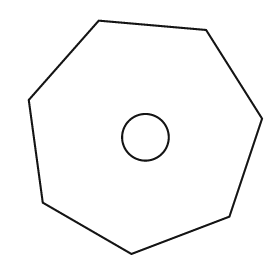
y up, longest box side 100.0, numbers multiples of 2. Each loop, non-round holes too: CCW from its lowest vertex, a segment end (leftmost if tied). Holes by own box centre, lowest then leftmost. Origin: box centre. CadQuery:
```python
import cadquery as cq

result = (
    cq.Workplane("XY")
    .moveTo(-6.0, -50.0)
    .lineTo(36.0, -34.0)
    .lineTo(50.0, 8.0)
    .lineTo(26.0, 46.0)
    .lineTo(-20.0, 50.0)
    .lineTo(-50.0, 16.0)
    .lineTo(-44.0, -28.0)
    .close()
    .moveTo(0.0, 0.0)
    .circle(10.0)
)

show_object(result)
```